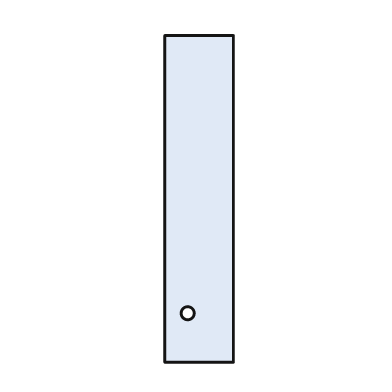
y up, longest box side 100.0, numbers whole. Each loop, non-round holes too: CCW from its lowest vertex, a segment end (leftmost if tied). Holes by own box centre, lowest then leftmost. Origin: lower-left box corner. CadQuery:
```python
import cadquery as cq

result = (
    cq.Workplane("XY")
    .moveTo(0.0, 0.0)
    .lineTo(21.0, 0.0)
    .lineTo(21.0, 100.0)
    .lineTo(0.0, 100.0)
    .close()
    .moveTo(7.0, 15.0)
    .circle(2.0)
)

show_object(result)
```